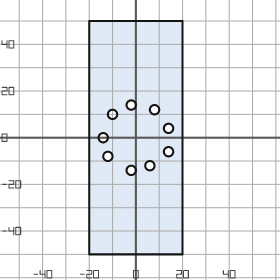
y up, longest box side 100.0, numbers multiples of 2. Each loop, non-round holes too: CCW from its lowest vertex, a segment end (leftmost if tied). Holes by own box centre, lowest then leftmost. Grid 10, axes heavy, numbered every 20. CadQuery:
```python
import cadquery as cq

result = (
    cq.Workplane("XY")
    .moveTo(-20.0, -50.0)
    .lineTo(20.0, -50.0)
    .lineTo(20.0, 50.0)
    .lineTo(-20.0, 50.0)
    .close()
    .moveTo(-2.0, -14.0)
    .circle(2.0)
    .moveTo(6.0, -12.0)
    .circle(2.0)
    .moveTo(-12.0, -8.0)
    .circle(2.0)
    .moveTo(14.0, -6.0)
    .circle(2.0)
    .moveTo(-14.0, 0.0)
    .circle(2.0)
    .moveTo(14.0, 4.0)
    .circle(2.0)
    .moveTo(-10.0, 10.0)
    .circle(2.0)
    .moveTo(8.0, 12.0)
    .circle(2.0)
    .moveTo(-2.0, 14.0)
    .circle(2.0)
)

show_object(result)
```